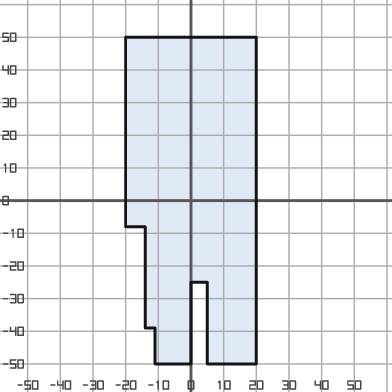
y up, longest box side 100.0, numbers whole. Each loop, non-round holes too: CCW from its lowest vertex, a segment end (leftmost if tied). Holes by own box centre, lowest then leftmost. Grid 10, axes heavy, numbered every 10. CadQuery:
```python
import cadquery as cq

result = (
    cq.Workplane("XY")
    .moveTo(-11.0, -50.0)
    .lineTo(0.0, -50.0)
    .lineTo(0.0, -25.0)
    .lineTo(5.0, -25.0)
    .lineTo(5.0, -50.0)
    .lineTo(20.0, -50.0)
    .lineTo(20.0, 50.0)
    .lineTo(-20.0, 50.0)
    .lineTo(-20.0, -8.0)
    .lineTo(-14.0, -8.0)
    .lineTo(-14.0, -39.0)
    .lineTo(-11.0, -39.0)
    .close()
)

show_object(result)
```